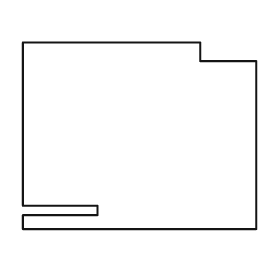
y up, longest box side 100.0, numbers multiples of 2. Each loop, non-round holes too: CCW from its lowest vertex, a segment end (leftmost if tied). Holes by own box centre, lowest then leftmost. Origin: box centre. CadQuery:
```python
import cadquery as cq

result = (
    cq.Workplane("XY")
    .moveTo(-50.0, -40.0)
    .lineTo(50.0, -40.0)
    .lineTo(50.0, 32.0)
    .lineTo(26.0, 32.0)
    .lineTo(26.0, 40.0)
    .lineTo(-50.0, 40.0)
    .lineTo(-50.0, -30.0)
    .lineTo(-18.0, -30.0)
    .lineTo(-18.0, -34.0)
    .lineTo(-50.0, -34.0)
    .close()
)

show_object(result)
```